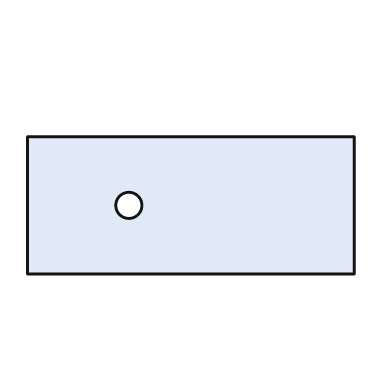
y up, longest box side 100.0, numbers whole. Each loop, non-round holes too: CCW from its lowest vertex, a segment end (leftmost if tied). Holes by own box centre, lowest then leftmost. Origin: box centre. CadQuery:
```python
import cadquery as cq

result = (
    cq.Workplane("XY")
    .moveTo(-50.0, -21.0)
    .lineTo(50.0, -21.0)
    .lineTo(50.0, 21.0)
    .lineTo(-50.0, 21.0)
    .close()
    .moveTo(-19.0, 0.0)
    .circle(4.0)
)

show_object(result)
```